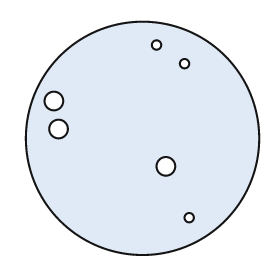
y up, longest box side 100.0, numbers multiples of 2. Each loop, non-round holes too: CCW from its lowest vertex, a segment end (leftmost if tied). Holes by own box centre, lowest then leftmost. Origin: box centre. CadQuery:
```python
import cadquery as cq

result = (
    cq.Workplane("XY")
    .moveTo(0.0, 0.0)
    .circle(50.0)
    .moveTo(20.0, -34.0)
    .circle(2.0)
    .moveTo(10.0, -12.0)
    .circle(4.0)
    .moveTo(-36.0, 4.0)
    .circle(4.0)
    .moveTo(-38.0, 16.0)
    .circle(4.0)
    .moveTo(18.0, 32.0)
    .circle(2.0)
    .moveTo(6.0, 40.0)
    .circle(2.0)
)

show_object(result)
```